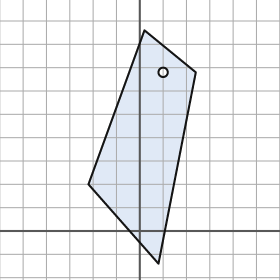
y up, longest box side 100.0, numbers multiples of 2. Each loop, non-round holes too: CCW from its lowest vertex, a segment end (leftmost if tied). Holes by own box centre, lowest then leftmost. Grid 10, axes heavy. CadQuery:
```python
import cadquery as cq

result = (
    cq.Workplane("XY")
    .moveTo(8.0, -14.0)
    .lineTo(24.0, 68.0)
    .lineTo(2.0, 86.0)
    .lineTo(-22.0, 20.0)
    .close()
    .moveTo(10.0, 68.0)
    .circle(2.0)
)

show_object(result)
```